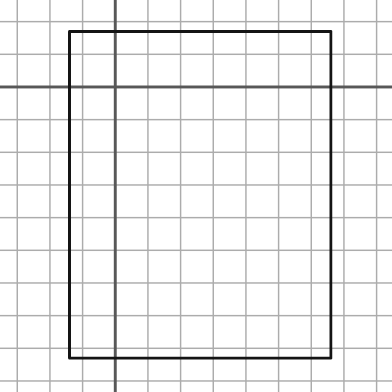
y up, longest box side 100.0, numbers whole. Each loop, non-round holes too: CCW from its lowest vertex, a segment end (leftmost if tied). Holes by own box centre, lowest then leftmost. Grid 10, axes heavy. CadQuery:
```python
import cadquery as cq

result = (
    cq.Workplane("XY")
    .moveTo(-14.0, -83.0)
    .lineTo(66.0, -83.0)
    .lineTo(66.0, 17.0)
    .lineTo(-14.0, 17.0)
    .close()
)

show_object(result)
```